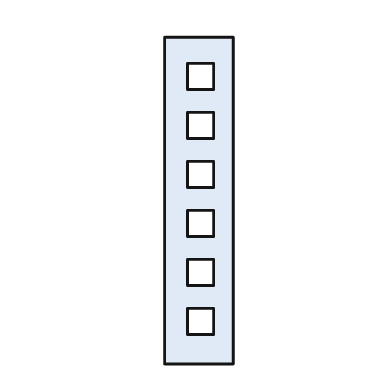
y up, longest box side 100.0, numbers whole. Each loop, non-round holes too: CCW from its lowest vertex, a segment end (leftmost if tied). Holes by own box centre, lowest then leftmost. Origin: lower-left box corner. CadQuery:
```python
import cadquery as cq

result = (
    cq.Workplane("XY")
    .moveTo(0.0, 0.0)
    .lineTo(21.0, 0.0)
    .lineTo(21.0, 100.0)
    .lineTo(0.0, 100.0)
    .close()
    .moveTo(7.0, 9.0)
    .lineTo(15.0, 9.0)
    .lineTo(15.0, 17.0)
    .lineTo(7.0, 17.0)
    .close()
    .moveTo(7.0, 24.0)
    .lineTo(15.0, 24.0)
    .lineTo(15.0, 32.0)
    .lineTo(7.0, 32.0)
    .close()
    .moveTo(7.0, 39.0)
    .lineTo(15.0, 39.0)
    .lineTo(15.0, 47.0)
    .lineTo(7.0, 47.0)
    .close()
    .moveTo(7.0, 54.0)
    .lineTo(15.0, 54.0)
    .lineTo(15.0, 62.0)
    .lineTo(7.0, 62.0)
    .close()
    .moveTo(7.0, 69.0)
    .lineTo(15.0, 69.0)
    .lineTo(15.0, 77.0)
    .lineTo(7.0, 77.0)
    .close()
    .moveTo(7.0, 84.0)
    .lineTo(15.0, 84.0)
    .lineTo(15.0, 92.0)
    .lineTo(7.0, 92.0)
    .close()
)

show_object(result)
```